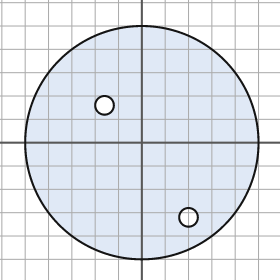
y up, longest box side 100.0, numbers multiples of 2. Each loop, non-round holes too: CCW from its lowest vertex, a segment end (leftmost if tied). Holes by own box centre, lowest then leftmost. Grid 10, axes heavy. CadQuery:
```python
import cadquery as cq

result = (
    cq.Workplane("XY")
    .moveTo(0.0, 0.0)
    .circle(50.0)
    .moveTo(20.0, -32.0)
    .circle(4.0)
    .moveTo(-16.0, 16.0)
    .circle(4.0)
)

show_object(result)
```